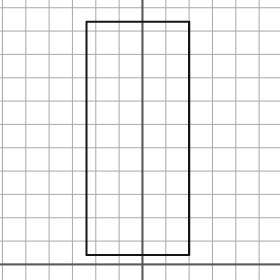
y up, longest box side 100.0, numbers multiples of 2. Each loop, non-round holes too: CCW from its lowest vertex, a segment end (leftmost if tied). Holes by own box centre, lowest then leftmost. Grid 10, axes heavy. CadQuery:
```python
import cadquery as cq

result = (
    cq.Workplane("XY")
    .moveTo(-24.0, 4.0)
    .lineTo(20.0, 4.0)
    .lineTo(20.0, 104.0)
    .lineTo(-24.0, 104.0)
    .close()
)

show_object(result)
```